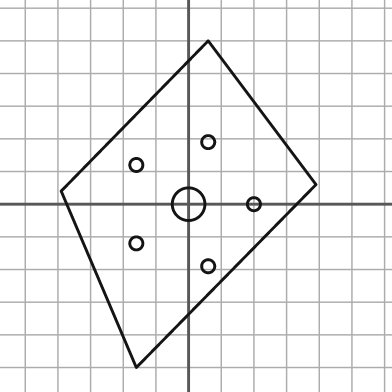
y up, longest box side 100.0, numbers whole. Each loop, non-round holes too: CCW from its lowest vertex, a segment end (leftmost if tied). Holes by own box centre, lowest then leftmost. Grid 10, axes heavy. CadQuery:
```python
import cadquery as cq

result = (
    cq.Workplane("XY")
    .moveTo(-16.0, -50.0)
    .lineTo(39.0, 6.0)
    .lineTo(6.0, 50.0)
    .lineTo(-39.0, 4.0)
    .close()
    .moveTo(6.0, -19.0)
    .circle(2.0)
    .moveTo(-16.0, -12.0)
    .circle(2.0)
    .moveTo(0.0, 0.0)
    .circle(5.0)
    .moveTo(20.0, 0.0)
    .circle(2.0)
    .moveTo(-16.0, 12.0)
    .circle(2.0)
    .moveTo(6.0, 19.0)
    .circle(2.0)
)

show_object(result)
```